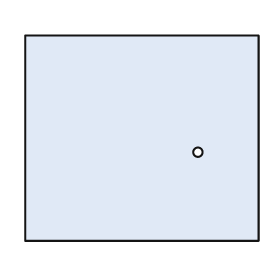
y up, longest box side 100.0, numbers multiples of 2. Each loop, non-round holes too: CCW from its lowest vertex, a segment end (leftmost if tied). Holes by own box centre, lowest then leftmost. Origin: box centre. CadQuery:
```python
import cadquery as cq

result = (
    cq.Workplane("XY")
    .moveTo(-50.0, -44.0)
    .lineTo(50.0, -44.0)
    .lineTo(50.0, 44.0)
    .lineTo(-50.0, 44.0)
    .close()
    .moveTo(24.0, -6.0)
    .circle(2.0)
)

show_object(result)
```